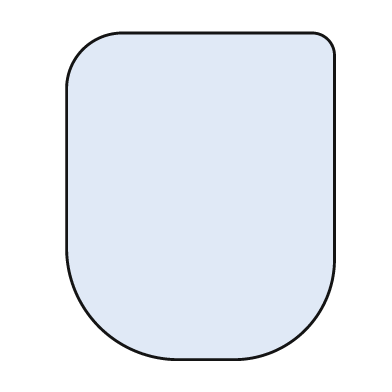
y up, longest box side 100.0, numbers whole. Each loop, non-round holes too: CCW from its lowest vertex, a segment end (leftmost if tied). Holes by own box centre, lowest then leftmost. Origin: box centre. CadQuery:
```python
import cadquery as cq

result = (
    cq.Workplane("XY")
    .moveTo(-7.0, -50.0)
    .lineTo(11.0, -50.0)
    .threePointArc((32.0, -41.0), (41.0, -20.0))
    .lineTo(41.0, 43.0)
    .threePointArc((39.0, 48.0), (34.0, 50.0))
    .lineTo(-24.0, 50.0)
    .threePointArc((-36.0, 45.0), (-41.0, 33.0))
    .lineTo(-41.0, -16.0)
    .threePointArc((-31.0, -40.0), (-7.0, -50.0))
    .close()
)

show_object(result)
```